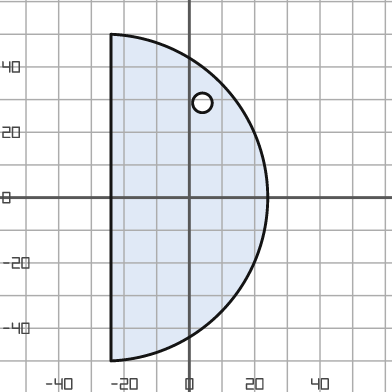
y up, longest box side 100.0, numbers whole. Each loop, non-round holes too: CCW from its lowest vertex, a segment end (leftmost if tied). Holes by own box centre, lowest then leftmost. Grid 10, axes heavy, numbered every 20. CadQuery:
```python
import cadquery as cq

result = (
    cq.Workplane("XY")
    .moveTo(-24.0, -50.0)
    .threePointArc((24.0, 0.0), (-24.0, 50.0))
    .close()
    .moveTo(4.0, 29.0)
    .circle(3.0)
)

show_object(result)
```